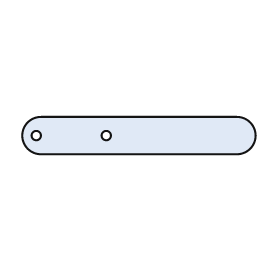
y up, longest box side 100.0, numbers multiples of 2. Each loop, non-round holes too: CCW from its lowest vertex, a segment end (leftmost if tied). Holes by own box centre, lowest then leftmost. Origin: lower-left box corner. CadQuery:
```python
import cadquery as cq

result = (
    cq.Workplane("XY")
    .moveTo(8.0, 0.0)
    .lineTo(92.0, 0.0)
    .threePointArc((100.0, 8.0), (92.0, 16.0))
    .lineTo(8.0, 16.0)
    .threePointArc((0.0, 8.0), (8.0, 0.0))
    .close()
    .moveTo(6.0, 8.0)
    .circle(2.0)
    .moveTo(36.0, 8.0)
    .circle(2.0)
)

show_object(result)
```